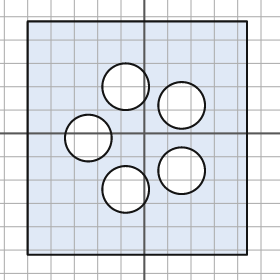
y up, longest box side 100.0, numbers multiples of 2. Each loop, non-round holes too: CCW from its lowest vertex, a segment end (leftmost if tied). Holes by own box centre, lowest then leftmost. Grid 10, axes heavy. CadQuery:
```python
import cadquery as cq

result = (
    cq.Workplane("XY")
    .moveTo(-50.0, -52.0)
    .lineTo(44.0, -52.0)
    .lineTo(44.0, 48.0)
    .lineTo(-50.0, 48.0)
    .close()
    .moveTo(-8.0, -24.0)
    .circle(10.0)
    .moveTo(16.0, -16.0)
    .circle(10.0)
    .moveTo(-24.0, -2.0)
    .circle(10.0)
    .moveTo(16.0, 12.0)
    .circle(10.0)
    .moveTo(-8.0, 20.0)
    .circle(10.0)
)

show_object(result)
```